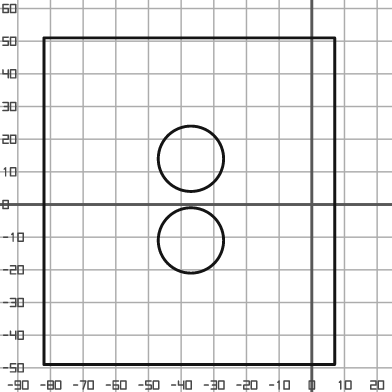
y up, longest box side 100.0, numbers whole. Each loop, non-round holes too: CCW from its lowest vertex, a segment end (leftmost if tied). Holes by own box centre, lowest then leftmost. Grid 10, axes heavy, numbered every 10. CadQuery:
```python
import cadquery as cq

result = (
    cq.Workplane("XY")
    .moveTo(-82.0, -49.0)
    .lineTo(7.0, -49.0)
    .lineTo(7.0, 51.0)
    .lineTo(-82.0, 51.0)
    .close()
    .moveTo(-37.0, -11.0)
    .circle(10.0)
    .moveTo(-37.0, 14.0)
    .circle(10.0)
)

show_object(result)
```